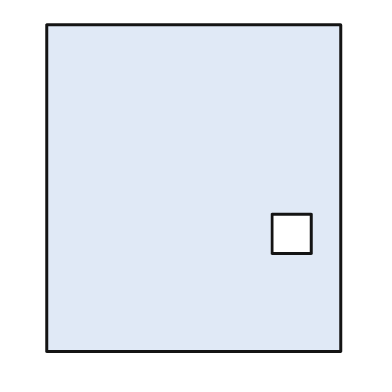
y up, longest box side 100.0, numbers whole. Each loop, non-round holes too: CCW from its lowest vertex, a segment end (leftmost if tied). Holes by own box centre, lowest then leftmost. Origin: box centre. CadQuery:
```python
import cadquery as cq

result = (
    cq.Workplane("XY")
    .moveTo(-45.0, -50.0)
    .lineTo(45.0, -50.0)
    .lineTo(45.0, 50.0)
    .lineTo(-45.0, 50.0)
    .close()
    .moveTo(24.0, -20.0)
    .lineTo(36.0, -20.0)
    .lineTo(36.0, -8.0)
    .lineTo(24.0, -8.0)
    .close()
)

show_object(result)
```